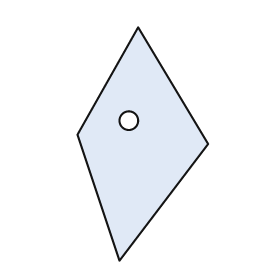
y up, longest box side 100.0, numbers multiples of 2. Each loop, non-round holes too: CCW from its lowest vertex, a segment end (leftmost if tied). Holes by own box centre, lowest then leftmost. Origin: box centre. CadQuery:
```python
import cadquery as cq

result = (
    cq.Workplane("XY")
    .moveTo(-10.0, -50.0)
    .lineTo(28.0, 0.0)
    .lineTo(-2.0, 50.0)
    .lineTo(-28.0, 4.0)
    .close()
    .moveTo(-6.0, 10.0)
    .circle(4.0)
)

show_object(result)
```